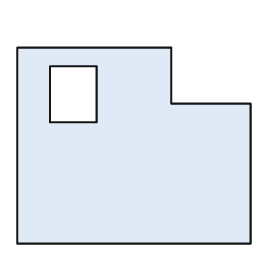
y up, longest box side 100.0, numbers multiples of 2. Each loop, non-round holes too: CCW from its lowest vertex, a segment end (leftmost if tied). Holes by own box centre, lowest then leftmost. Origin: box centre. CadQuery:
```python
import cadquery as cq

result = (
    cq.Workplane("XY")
    .moveTo(-50.0, -42.0)
    .lineTo(50.0, -42.0)
    .lineTo(50.0, 18.0)
    .lineTo(16.0, 18.0)
    .lineTo(16.0, 42.0)
    .lineTo(-50.0, 42.0)
    .close()
    .moveTo(-36.0, 10.0)
    .lineTo(-16.0, 10.0)
    .lineTo(-16.0, 34.0)
    .lineTo(-36.0, 34.0)
    .close()
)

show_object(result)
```